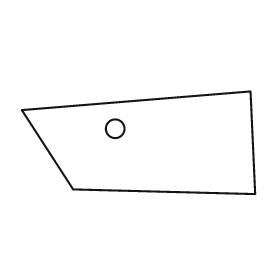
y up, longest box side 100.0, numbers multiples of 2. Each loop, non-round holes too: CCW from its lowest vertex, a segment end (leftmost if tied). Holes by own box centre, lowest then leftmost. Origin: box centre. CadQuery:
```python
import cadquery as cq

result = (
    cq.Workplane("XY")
    .moveTo(50.0, -22.0)
    .lineTo(48.0, 22.0)
    .lineTo(-50.0, 14.0)
    .lineTo(-28.0, -20.0)
    .close()
    .moveTo(-10.0, 6.0)
    .circle(4.0)
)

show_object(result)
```